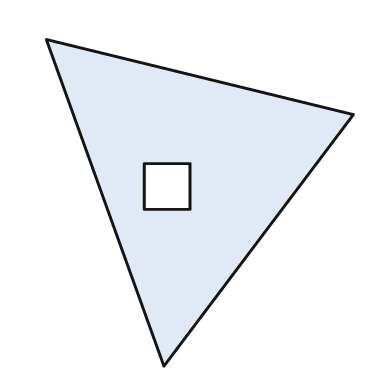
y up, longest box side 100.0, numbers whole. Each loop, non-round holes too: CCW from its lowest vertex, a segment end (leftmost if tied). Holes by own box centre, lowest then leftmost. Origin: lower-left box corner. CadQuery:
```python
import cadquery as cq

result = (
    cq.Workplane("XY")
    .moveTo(36.0, 0.0)
    .lineTo(94.0, 77.0)
    .lineTo(0.0, 100.0)
    .close()
    .moveTo(30.0, 48.0)
    .lineTo(44.0, 48.0)
    .lineTo(44.0, 62.0)
    .lineTo(30.0, 62.0)
    .close()
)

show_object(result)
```